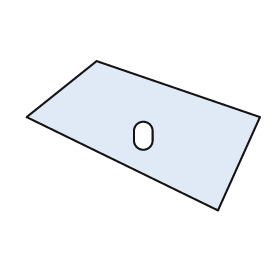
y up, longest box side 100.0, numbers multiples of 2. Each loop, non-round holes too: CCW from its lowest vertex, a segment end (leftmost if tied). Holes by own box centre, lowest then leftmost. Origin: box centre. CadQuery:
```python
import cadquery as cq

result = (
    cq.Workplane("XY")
    .moveTo(32.0, -32.0)
    .lineTo(50.0, 8.0)
    .lineTo(-20.0, 32.0)
    .lineTo(-50.0, 8.0)
    .close()
    .moveTo(-4.0, -2.0)
    .threePointArc((0.0, -6.0), (4.0, -2.0))
    .lineTo(4.0, 2.0)
    .threePointArc((0.0, 6.0), (-4.0, 2.0))
    .close()
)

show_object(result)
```